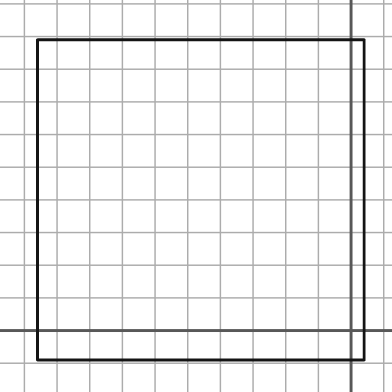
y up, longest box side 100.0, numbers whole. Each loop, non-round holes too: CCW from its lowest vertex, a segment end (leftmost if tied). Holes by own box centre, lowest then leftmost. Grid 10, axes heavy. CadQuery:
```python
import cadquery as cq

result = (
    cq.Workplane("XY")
    .moveTo(-96.0, -9.0)
    .lineTo(4.0, -9.0)
    .lineTo(4.0, 89.0)
    .lineTo(-96.0, 89.0)
    .close()
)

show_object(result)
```